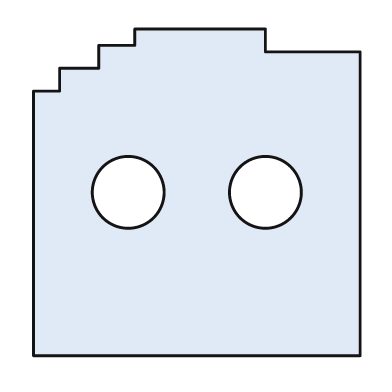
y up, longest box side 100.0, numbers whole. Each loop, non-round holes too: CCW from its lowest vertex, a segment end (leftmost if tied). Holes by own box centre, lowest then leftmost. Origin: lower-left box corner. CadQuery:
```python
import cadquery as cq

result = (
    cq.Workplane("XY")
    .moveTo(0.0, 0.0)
    .lineTo(100.0, 0.0)
    .lineTo(100.0, 93.0)
    .lineTo(71.0, 93.0)
    .lineTo(71.0, 100.0)
    .lineTo(31.0, 100.0)
    .lineTo(31.0, 95.0)
    .lineTo(20.0, 95.0)
    .lineTo(20.0, 88.0)
    .lineTo(8.0, 88.0)
    .lineTo(8.0, 81.0)
    .lineTo(0.0, 81.0)
    .close()
    .moveTo(29.0, 50.0)
    .circle(11.0)
    .moveTo(71.0, 50.0)
    .circle(11.0)
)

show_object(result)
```